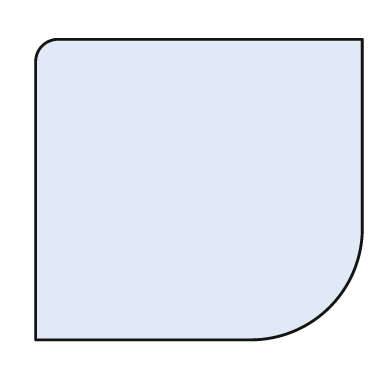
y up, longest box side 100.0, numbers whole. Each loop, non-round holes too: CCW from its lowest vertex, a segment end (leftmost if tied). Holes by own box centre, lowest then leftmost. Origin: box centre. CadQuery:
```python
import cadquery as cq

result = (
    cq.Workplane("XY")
    .moveTo(-50.0, -46.0)
    .lineTo(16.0, -46.0)
    .threePointArc((40.0, -36.0), (50.0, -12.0))
    .lineTo(50.0, 46.0)
    .lineTo(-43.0, 46.0)
    .threePointArc((-48.0, 44.0), (-50.0, 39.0))
    .close()
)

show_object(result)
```